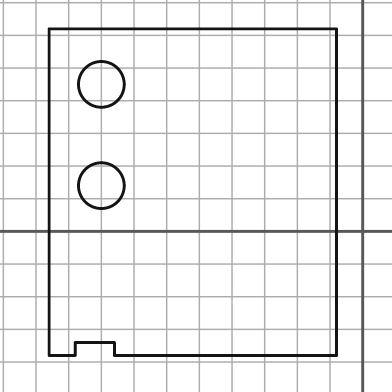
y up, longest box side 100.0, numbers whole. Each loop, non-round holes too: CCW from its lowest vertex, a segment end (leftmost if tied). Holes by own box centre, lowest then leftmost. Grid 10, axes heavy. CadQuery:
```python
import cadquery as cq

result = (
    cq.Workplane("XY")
    .moveTo(-96.0, -38.0)
    .lineTo(-88.0, -38.0)
    .lineTo(-88.0, -34.0)
    .lineTo(-76.0, -34.0)
    .lineTo(-76.0, -38.0)
    .lineTo(-8.0, -38.0)
    .lineTo(-8.0, 62.0)
    .lineTo(-96.0, 62.0)
    .close()
    .moveTo(-80.0, 14.0)
    .circle(7.0)
    .moveTo(-80.0, 45.0)
    .circle(7.0)
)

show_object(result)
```